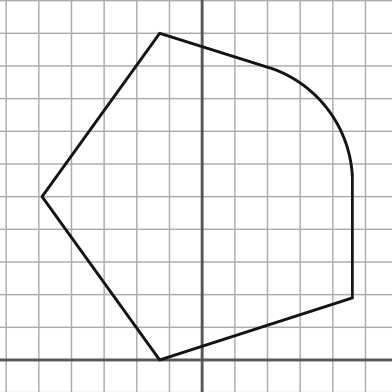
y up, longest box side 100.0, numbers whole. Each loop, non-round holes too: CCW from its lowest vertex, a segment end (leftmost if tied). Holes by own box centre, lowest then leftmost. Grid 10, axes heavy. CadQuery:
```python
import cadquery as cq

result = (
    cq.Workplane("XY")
    .moveTo(-13.0, 0.0)
    .lineTo(46.0, 19.0)
    .lineTo(46.0, 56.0)
    .threePointArc((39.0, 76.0), (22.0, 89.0))
    .lineTo(-13.0, 100.0)
    .lineTo(-49.0, 50.0)
    .close()
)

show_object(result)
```